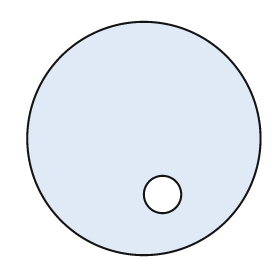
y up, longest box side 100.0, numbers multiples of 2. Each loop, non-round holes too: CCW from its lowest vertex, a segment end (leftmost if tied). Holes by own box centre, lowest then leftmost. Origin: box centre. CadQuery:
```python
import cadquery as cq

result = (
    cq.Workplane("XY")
    .moveTo(0.0, 0.0)
    .circle(50.0)
    .moveTo(8.0, -24.0)
    .circle(8.0)
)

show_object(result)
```